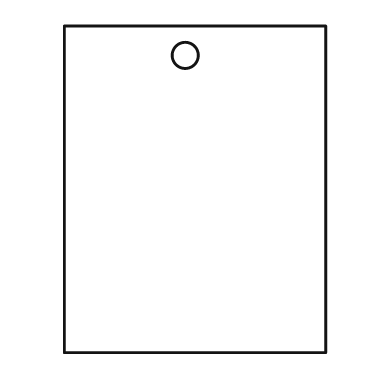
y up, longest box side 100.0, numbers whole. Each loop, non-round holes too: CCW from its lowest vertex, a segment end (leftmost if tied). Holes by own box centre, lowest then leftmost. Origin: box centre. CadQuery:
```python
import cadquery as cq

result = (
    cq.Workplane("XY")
    .moveTo(-40.0, -50.0)
    .lineTo(40.0, -50.0)
    .lineTo(40.0, 50.0)
    .lineTo(-40.0, 50.0)
    .close()
    .moveTo(-3.0, 41.0)
    .circle(4.0)
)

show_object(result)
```